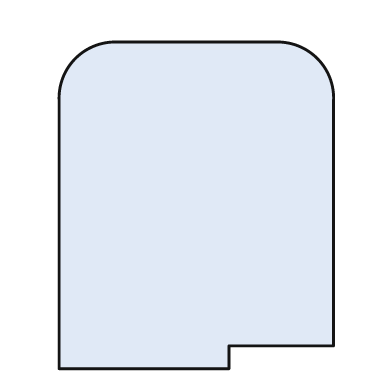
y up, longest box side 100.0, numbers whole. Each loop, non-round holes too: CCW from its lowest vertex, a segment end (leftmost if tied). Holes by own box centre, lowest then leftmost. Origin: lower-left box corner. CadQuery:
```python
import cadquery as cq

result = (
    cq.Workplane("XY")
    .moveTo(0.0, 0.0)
    .lineTo(52.0, 0.0)
    .lineTo(52.0, 7.0)
    .lineTo(84.0, 7.0)
    .lineTo(84.0, 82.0)
    .threePointArc((79.0, 95.0), (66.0, 100.0))
    .lineTo(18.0, 100.0)
    .threePointArc((5.0, 95.0), (0.0, 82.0))
    .close()
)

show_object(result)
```